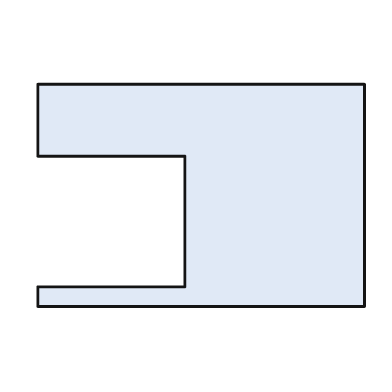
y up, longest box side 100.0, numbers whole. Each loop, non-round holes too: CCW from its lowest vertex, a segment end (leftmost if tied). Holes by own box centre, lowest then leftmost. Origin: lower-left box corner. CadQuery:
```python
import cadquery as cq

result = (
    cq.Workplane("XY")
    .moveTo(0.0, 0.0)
    .lineTo(100.0, 0.0)
    .lineTo(100.0, 68.0)
    .lineTo(0.0, 68.0)
    .lineTo(0.0, 46.0)
    .lineTo(45.0, 46.0)
    .lineTo(45.0, 6.0)
    .lineTo(0.0, 6.0)
    .close()
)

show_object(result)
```